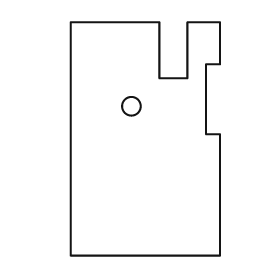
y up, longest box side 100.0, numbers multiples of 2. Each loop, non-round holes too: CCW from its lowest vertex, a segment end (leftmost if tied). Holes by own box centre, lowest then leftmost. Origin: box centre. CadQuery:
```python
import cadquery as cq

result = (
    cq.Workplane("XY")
    .moveTo(-32.0, -50.0)
    .lineTo(32.0, -50.0)
    .lineTo(32.0, 2.0)
    .lineTo(26.0, 2.0)
    .lineTo(26.0, 32.0)
    .lineTo(32.0, 32.0)
    .lineTo(32.0, 50.0)
    .lineTo(18.0, 50.0)
    .lineTo(18.0, 26.0)
    .lineTo(6.0, 26.0)
    .lineTo(6.0, 50.0)
    .lineTo(-32.0, 50.0)
    .close()
    .moveTo(-6.0, 14.0)
    .circle(4.0)
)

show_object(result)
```